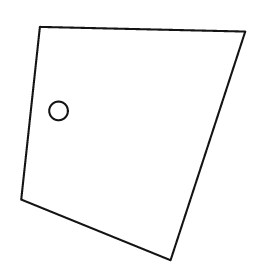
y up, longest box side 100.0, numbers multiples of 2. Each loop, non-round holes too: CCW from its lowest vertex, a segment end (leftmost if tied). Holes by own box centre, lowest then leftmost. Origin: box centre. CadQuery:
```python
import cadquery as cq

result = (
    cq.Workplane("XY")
    .moveTo(16.0, -50.0)
    .lineTo(48.0, 48.0)
    .lineTo(-40.0, 50.0)
    .lineTo(-48.0, -24.0)
    .close()
    .moveTo(-32.0, 14.0)
    .circle(4.0)
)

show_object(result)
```